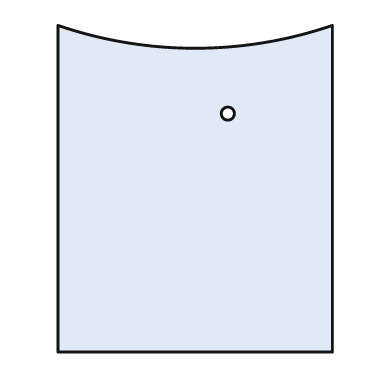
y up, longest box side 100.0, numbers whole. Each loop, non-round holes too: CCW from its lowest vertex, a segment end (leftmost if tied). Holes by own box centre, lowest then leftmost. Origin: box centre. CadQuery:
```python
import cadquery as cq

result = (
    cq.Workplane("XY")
    .moveTo(-42.0, -50.0)
    .lineTo(42.0, -50.0)
    .lineTo(42.0, 50.0)
    .threePointArc((0.0, 43.0), (-42.0, 50.0))
    .close()
    .moveTo(10.0, 23.0)
    .circle(2.0)
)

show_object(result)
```